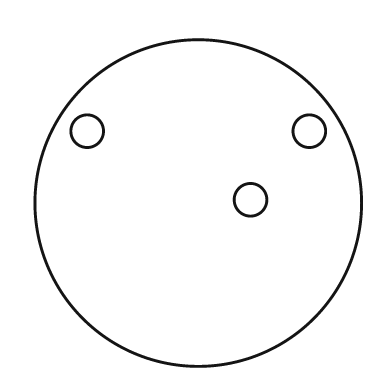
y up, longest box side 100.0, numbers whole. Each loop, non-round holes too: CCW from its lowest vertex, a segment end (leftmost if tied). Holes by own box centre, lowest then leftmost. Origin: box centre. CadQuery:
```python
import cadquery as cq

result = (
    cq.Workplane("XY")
    .moveTo(0.0, 0.0)
    .circle(50.0)
    .moveTo(16.0, 1.0)
    .circle(5.0)
    .moveTo(-34.0, 22.0)
    .circle(5.0)
    .moveTo(34.0, 22.0)
    .circle(5.0)
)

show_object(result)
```